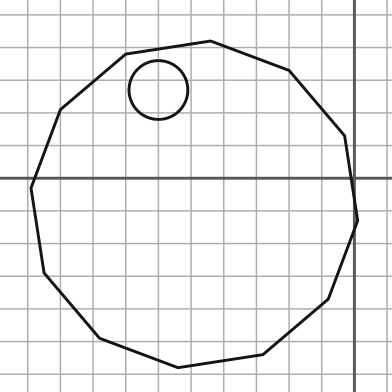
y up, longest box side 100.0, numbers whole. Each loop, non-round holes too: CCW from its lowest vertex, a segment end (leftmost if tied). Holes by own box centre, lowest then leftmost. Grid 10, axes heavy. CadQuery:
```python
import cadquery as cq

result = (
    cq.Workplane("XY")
    .moveTo(-54.0, -58.0)
    .lineTo(-28.0, -54.0)
    .lineTo(-8.0, -37.0)
    .lineTo(1.0, -13.0)
    .lineTo(-3.0, 13.0)
    .lineTo(-20.0, 33.0)
    .lineTo(-44.0, 42.0)
    .lineTo(-70.0, 38.0)
    .lineTo(-90.0, 21.0)
    .lineTo(-99.0, -3.0)
    .lineTo(-95.0, -29.0)
    .lineTo(-78.0, -49.0)
    .close()
    .moveTo(-60.0, 27.0)
    .circle(9.0)
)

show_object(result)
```